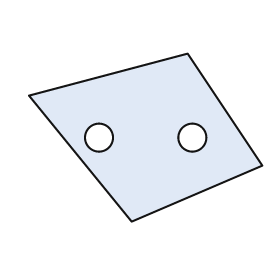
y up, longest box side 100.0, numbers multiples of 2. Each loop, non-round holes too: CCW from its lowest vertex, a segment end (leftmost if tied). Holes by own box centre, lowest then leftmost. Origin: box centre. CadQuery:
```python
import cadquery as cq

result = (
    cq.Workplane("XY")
    .moveTo(-6.0, -36.0)
    .lineTo(50.0, -12.0)
    .lineTo(18.0, 36.0)
    .lineTo(-50.0, 18.0)
    .close()
    .moveTo(-20.0, 0.0)
    .circle(6.0)
    .moveTo(20.0, 0.0)
    .circle(6.0)
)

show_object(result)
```